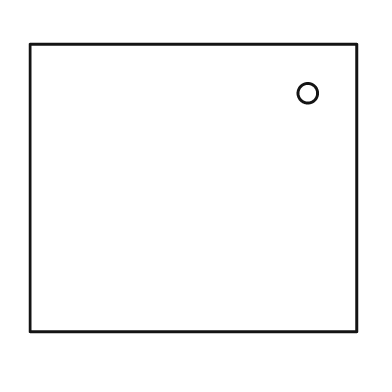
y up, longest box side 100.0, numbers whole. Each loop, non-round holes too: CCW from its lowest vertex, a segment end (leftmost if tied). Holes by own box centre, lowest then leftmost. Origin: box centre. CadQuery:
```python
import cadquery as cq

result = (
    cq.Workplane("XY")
    .moveTo(-50.0, -44.0)
    .lineTo(50.0, -44.0)
    .lineTo(50.0, 44.0)
    .lineTo(-50.0, 44.0)
    .close()
    .moveTo(35.0, 29.0)
    .circle(3.0)
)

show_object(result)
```